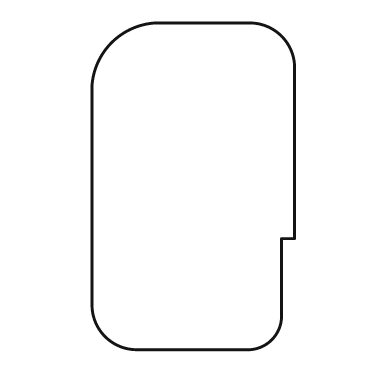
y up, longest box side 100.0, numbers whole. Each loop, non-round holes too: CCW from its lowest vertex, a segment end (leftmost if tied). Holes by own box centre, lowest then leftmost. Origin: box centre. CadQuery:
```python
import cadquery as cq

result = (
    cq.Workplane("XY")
    .moveTo(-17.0, -50.0)
    .lineTo(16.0, -50.0)
    .threePointArc((24.0, -47.0), (27.0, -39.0))
    .lineTo(27.0, -16.0)
    .lineTo(31.0, -16.0)
    .lineTo(31.0, 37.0)
    .threePointArc((27.0, 46.0), (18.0, 50.0))
    .lineTo(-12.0, 50.0)
    .threePointArc((-25.0, 44.0), (-31.0, 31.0))
    .lineTo(-31.0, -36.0)
    .threePointArc((-27.0, -46.0), (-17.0, -50.0))
    .close()
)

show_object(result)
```